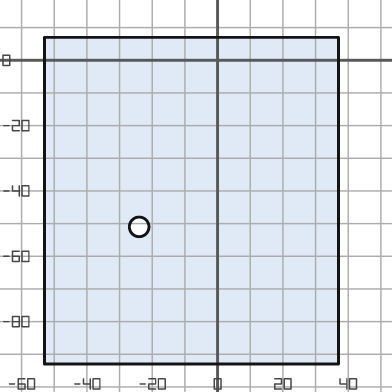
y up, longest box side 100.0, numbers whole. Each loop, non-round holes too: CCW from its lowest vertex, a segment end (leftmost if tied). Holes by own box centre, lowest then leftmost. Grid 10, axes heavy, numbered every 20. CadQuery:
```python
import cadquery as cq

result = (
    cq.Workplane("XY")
    .moveTo(-53.0, -93.0)
    .lineTo(37.0, -93.0)
    .lineTo(37.0, 7.0)
    .lineTo(-53.0, 7.0)
    .close()
    .moveTo(-24.0, -51.0)
    .circle(3.0)
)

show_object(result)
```